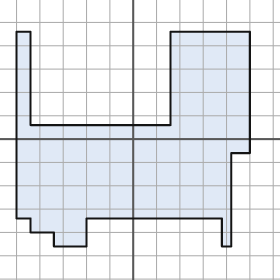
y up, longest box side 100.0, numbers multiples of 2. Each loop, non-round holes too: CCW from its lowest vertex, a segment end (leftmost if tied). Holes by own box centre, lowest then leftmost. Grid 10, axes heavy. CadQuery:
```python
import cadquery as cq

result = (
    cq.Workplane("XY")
    .moveTo(-34.0, -46.0)
    .lineTo(-20.0, -46.0)
    .lineTo(-20.0, -34.0)
    .lineTo(38.0, -34.0)
    .lineTo(38.0, -46.0)
    .lineTo(42.0, -46.0)
    .lineTo(42.0, -6.0)
    .lineTo(50.0, -6.0)
    .lineTo(50.0, 46.0)
    .lineTo(16.0, 46.0)
    .lineTo(16.0, 6.0)
    .lineTo(-44.0, 6.0)
    .lineTo(-44.0, 46.0)
    .lineTo(-50.0, 46.0)
    .lineTo(-50.0, -34.0)
    .lineTo(-44.0, -34.0)
    .lineTo(-44.0, -40.0)
    .lineTo(-34.0, -40.0)
    .close()
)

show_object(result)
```